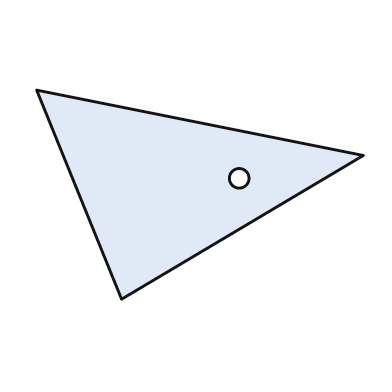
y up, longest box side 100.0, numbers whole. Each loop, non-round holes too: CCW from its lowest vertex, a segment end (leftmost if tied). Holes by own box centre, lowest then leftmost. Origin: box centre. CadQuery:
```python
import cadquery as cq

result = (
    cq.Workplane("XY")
    .moveTo(-24.0, -32.0)
    .lineTo(50.0, 12.0)
    .lineTo(-50.0, 32.0)
    .close()
    .moveTo(12.0, 5.0)
    .circle(3.0)
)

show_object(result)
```